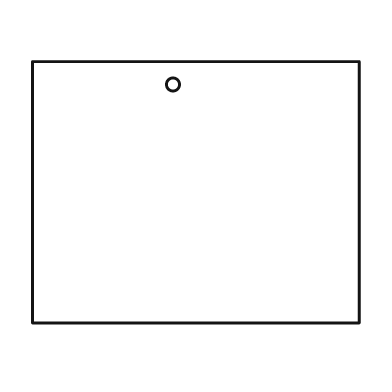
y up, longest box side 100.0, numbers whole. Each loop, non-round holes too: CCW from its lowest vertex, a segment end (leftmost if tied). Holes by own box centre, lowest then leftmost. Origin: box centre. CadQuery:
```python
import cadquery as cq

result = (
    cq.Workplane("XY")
    .moveTo(-50.0, -40.0)
    .lineTo(50.0, -40.0)
    .lineTo(50.0, 40.0)
    .lineTo(-50.0, 40.0)
    .close()
    .moveTo(-7.0, 33.0)
    .circle(2.0)
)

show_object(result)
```